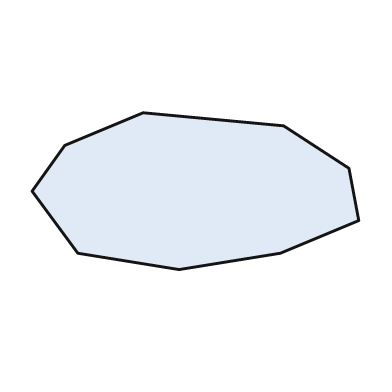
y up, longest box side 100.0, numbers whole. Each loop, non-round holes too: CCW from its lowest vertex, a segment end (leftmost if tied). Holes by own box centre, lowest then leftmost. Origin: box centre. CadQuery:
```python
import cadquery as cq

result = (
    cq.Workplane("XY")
    .moveTo(-5.0, -24.0)
    .lineTo(26.0, -19.0)
    .lineTo(50.0, -9.0)
    .lineTo(47.0, 7.0)
    .lineTo(27.0, 20.0)
    .lineTo(-16.0, 24.0)
    .lineTo(-40.0, 14.0)
    .lineTo(-50.0, 0.0)
    .lineTo(-36.0, -19.0)
    .close()
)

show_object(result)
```